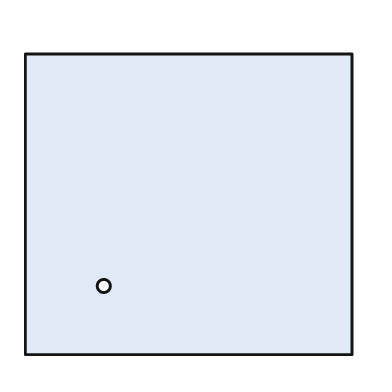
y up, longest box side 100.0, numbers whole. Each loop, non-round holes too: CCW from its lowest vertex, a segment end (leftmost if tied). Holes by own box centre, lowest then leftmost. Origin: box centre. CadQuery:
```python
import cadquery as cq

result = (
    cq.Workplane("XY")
    .moveTo(-50.0, -46.0)
    .lineTo(50.0, -46.0)
    .lineTo(50.0, 46.0)
    .lineTo(-50.0, 46.0)
    .close()
    .moveTo(-26.0, -25.0)
    .circle(2.0)
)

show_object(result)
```